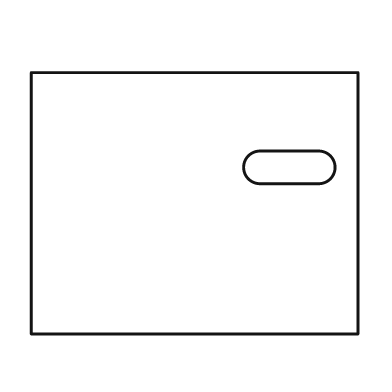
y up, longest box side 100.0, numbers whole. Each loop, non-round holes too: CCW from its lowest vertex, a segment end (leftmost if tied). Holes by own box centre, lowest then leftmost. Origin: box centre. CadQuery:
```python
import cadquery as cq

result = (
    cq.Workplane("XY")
    .moveTo(-50.0, -40.0)
    .lineTo(50.0, -40.0)
    .lineTo(50.0, 40.0)
    .lineTo(-50.0, 40.0)
    .close()
    .moveTo(20.0, 6.0)
    .lineTo(38.0, 6.0)
    .threePointArc((43.0, 11.0), (38.0, 16.0))
    .lineTo(20.0, 16.0)
    .threePointArc((15.0, 11.0), (20.0, 6.0))
    .close()
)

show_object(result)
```